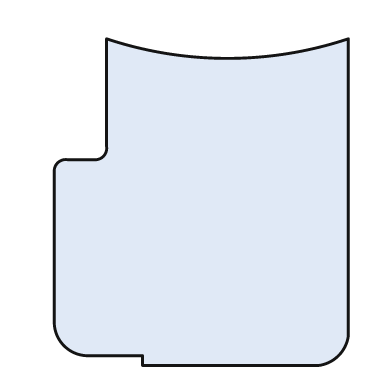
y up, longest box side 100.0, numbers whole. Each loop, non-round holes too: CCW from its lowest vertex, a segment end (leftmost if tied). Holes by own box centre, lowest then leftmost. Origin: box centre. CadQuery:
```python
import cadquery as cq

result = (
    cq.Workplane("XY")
    .moveTo(-18.0, -50.0)
    .lineTo(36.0, -50.0)
    .threePointArc((42.0, -47.0), (45.0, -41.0))
    .lineTo(45.0, 50.0)
    .threePointArc((8.0, 44.0), (-29.0, 50.0))
    .lineTo(-29.0, 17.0)
    .threePointArc((-30.0, 14.0), (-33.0, 13.0))
    .lineTo(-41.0, 13.0)
    .threePointArc((-44.0, 12.0), (-45.0, 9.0))
    .lineTo(-45.0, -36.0)
    .threePointArc((-42.0, -44.0), (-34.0, -47.0))
    .lineTo(-18.0, -47.0)
    .close()
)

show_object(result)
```